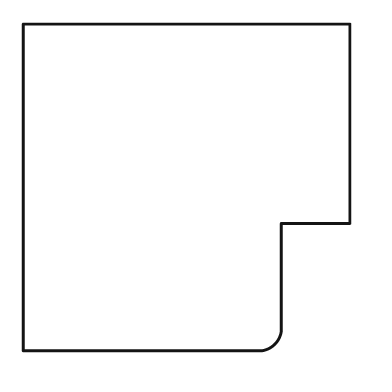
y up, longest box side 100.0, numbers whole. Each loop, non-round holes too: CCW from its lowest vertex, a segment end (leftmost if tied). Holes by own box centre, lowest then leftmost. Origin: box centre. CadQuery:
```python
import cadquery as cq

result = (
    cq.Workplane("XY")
    .moveTo(-50.0, -50.0)
    .lineTo(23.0, -50.0)
    .threePointArc((27.0, -48.0), (29.0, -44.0))
    .lineTo(29.0, -11.0)
    .lineTo(50.0, -11.0)
    .lineTo(50.0, 50.0)
    .lineTo(-50.0, 50.0)
    .close()
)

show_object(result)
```